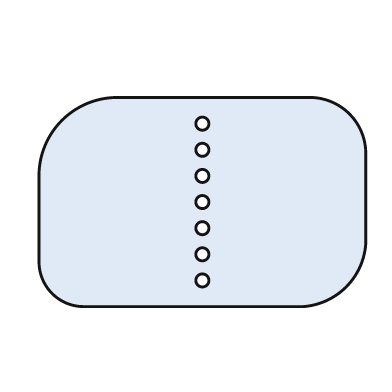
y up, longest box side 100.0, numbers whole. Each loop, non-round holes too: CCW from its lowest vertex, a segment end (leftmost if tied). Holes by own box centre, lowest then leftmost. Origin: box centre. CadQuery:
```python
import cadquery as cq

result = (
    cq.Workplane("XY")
    .moveTo(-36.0, -32.0)
    .lineTo(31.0, -32.0)
    .threePointArc((44.0, -26.0), (50.0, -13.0))
    .lineTo(50.0, 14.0)
    .threePointArc((45.0, 27.0), (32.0, 32.0))
    .lineTo(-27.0, 32.0)
    .threePointArc((-43.0, 25.0), (-50.0, 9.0))
    .lineTo(-50.0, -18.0)
    .threePointArc((-46.0, -28.0), (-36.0, -32.0))
    .close()
    .moveTo(0.0, -24.0)
    .circle(2.0)
    .moveTo(0.0, -16.0)
    .circle(2.0)
    .moveTo(0.0, -8.0)
    .circle(2.0)
    .moveTo(0.0, 0.0)
    .circle(2.0)
    .moveTo(0.0, 8.0)
    .circle(2.0)
    .moveTo(0.0, 16.0)
    .circle(2.0)
    .moveTo(0.0, 24.0)
    .circle(2.0)
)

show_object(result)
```